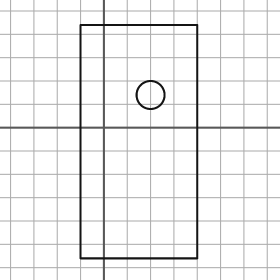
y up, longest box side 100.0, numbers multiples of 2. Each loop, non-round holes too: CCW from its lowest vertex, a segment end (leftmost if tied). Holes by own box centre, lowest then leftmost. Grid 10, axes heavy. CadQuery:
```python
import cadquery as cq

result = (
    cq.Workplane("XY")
    .moveTo(-10.0, -56.0)
    .lineTo(40.0, -56.0)
    .lineTo(40.0, 44.0)
    .lineTo(-10.0, 44.0)
    .close()
    .moveTo(20.0, 14.0)
    .circle(6.0)
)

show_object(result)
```